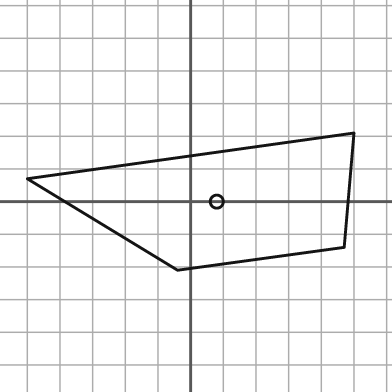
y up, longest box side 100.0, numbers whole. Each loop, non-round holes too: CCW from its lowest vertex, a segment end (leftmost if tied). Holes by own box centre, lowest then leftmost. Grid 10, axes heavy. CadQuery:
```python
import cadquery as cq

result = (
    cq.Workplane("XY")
    .moveTo(-4.0, -21.0)
    .lineTo(47.0, -14.0)
    .lineTo(50.0, 21.0)
    .lineTo(-50.0, 7.0)
    .close()
    .moveTo(8.0, 0.0)
    .circle(2.0)
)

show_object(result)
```